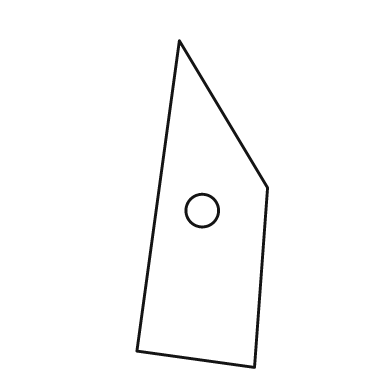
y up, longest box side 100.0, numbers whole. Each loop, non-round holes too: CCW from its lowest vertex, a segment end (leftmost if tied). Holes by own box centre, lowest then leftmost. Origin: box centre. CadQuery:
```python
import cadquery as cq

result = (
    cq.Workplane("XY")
    .moveTo(16.0, -50.0)
    .lineTo(20.0, 5.0)
    .lineTo(-7.0, 50.0)
    .lineTo(-20.0, -45.0)
    .close()
    .moveTo(0.0, -2.0)
    .circle(5.0)
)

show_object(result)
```